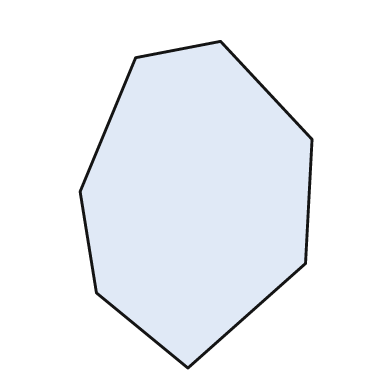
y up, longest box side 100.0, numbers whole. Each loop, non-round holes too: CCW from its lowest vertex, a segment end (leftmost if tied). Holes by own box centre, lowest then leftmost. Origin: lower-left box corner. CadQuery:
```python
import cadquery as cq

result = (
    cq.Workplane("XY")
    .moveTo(33.0, 0.0)
    .lineTo(69.0, 32.0)
    .lineTo(71.0, 70.0)
    .lineTo(43.0, 100.0)
    .lineTo(17.0, 95.0)
    .lineTo(0.0, 54.0)
    .lineTo(5.0, 23.0)
    .close()
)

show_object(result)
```